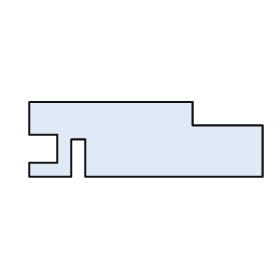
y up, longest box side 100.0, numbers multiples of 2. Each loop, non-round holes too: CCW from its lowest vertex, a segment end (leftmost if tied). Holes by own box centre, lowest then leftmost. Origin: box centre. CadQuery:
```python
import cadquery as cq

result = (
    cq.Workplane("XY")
    .moveTo(-50.0, -16.0)
    .lineTo(-32.0, -16.0)
    .lineTo(-32.0, 0.0)
    .lineTo(-26.0, 0.0)
    .lineTo(-26.0, -16.0)
    .lineTo(50.0, -16.0)
    .lineTo(50.0, 6.0)
    .lineTo(20.0, 6.0)
    .lineTo(20.0, 16.0)
    .lineTo(-50.0, 16.0)
    .lineTo(-50.0, 2.0)
    .lineTo(-38.0, 2.0)
    .lineTo(-38.0, -10.0)
    .lineTo(-50.0, -10.0)
    .close()
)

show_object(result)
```